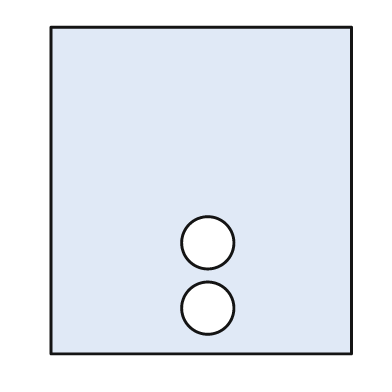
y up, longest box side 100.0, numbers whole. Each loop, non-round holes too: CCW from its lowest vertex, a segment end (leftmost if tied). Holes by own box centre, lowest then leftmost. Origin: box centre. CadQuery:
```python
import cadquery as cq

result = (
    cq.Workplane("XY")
    .moveTo(-46.0, -50.0)
    .lineTo(46.0, -50.0)
    .lineTo(46.0, 50.0)
    .lineTo(-46.0, 50.0)
    .close()
    .moveTo(2.0, -36.0)
    .circle(8.0)
    .moveTo(2.0, -16.0)
    .circle(8.0)
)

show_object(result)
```